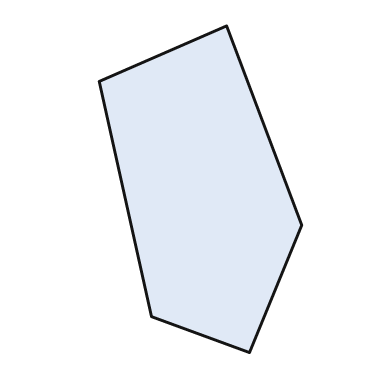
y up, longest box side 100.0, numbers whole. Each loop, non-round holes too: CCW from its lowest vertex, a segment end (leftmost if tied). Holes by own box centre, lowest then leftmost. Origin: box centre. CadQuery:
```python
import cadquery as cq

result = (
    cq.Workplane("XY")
    .moveTo(15.0, -50.0)
    .lineTo(31.0, -11.0)
    .lineTo(8.0, 50.0)
    .lineTo(-31.0, 33.0)
    .lineTo(-15.0, -39.0)
    .close()
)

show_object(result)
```